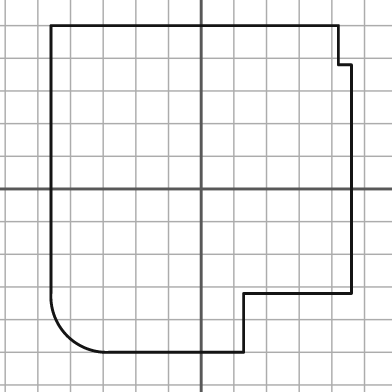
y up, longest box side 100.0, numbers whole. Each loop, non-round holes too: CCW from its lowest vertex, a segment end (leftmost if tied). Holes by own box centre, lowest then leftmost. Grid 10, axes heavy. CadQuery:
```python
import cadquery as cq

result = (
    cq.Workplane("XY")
    .moveTo(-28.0, -50.0)
    .lineTo(13.0, -50.0)
    .lineTo(13.0, -32.0)
    .lineTo(46.0, -32.0)
    .lineTo(46.0, 38.0)
    .lineTo(42.0, 38.0)
    .lineTo(42.0, 50.0)
    .lineTo(-46.0, 50.0)
    .lineTo(-46.0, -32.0)
    .threePointArc((-41.0, -45.0), (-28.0, -50.0))
    .close()
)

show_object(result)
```